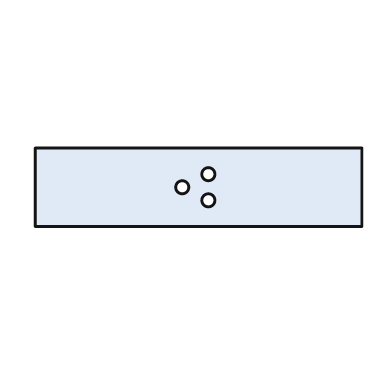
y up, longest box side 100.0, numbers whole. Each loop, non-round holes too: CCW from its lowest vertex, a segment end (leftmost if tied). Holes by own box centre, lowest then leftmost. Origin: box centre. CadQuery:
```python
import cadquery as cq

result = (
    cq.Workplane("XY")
    .moveTo(-50.0, -12.0)
    .lineTo(50.0, -12.0)
    .lineTo(50.0, 12.0)
    .lineTo(-50.0, 12.0)
    .close()
    .moveTo(3.0, -4.0)
    .circle(2.0)
    .moveTo(-5.0, 0.0)
    .circle(2.0)
    .moveTo(3.0, 4.0)
    .circle(2.0)
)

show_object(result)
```